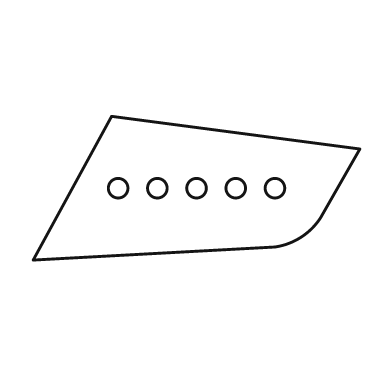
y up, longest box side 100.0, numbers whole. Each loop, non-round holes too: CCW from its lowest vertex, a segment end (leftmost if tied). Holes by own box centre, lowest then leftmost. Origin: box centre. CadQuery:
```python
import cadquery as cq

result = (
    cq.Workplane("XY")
    .moveTo(-50.0, -22.0)
    .lineTo(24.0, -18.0)
    .threePointArc((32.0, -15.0), (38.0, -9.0))
    .lineTo(50.0, 12.0)
    .lineTo(-26.0, 22.0)
    .close()
    .moveTo(-24.0, 0.0)
    .circle(3.0)
    .moveTo(-12.0, 0.0)
    .circle(3.0)
    .moveTo(0.0, 0.0)
    .circle(3.0)
    .moveTo(12.0, 0.0)
    .circle(3.0)
    .moveTo(24.0, 0.0)
    .circle(3.0)
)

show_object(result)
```